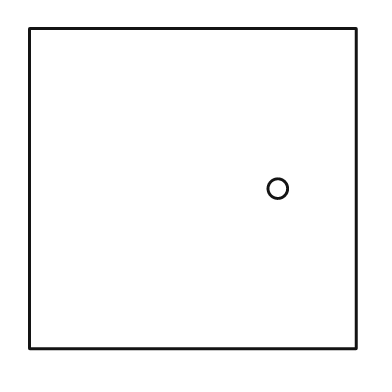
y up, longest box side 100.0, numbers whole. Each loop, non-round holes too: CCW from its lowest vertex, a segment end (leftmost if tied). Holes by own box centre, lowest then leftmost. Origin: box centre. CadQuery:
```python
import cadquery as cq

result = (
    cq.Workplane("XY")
    .moveTo(-50.0, -49.0)
    .lineTo(50.0, -49.0)
    .lineTo(50.0, 49.0)
    .lineTo(-50.0, 49.0)
    .close()
    .moveTo(26.0, 0.0)
    .circle(3.0)
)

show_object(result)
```